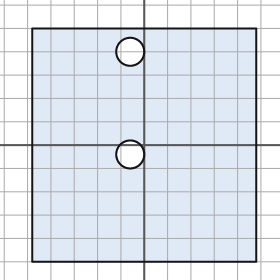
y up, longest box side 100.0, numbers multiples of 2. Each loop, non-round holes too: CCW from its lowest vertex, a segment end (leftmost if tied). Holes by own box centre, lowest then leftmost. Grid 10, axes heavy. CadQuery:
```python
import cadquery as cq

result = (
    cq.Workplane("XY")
    .moveTo(-48.0, -50.0)
    .lineTo(48.0, -50.0)
    .lineTo(48.0, 50.0)
    .lineTo(-48.0, 50.0)
    .close()
    .moveTo(-6.0, -4.0)
    .circle(6.0)
    .moveTo(-6.0, 40.0)
    .circle(6.0)
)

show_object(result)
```